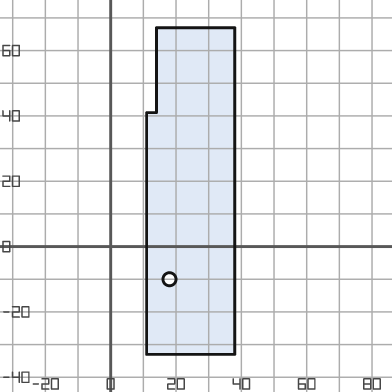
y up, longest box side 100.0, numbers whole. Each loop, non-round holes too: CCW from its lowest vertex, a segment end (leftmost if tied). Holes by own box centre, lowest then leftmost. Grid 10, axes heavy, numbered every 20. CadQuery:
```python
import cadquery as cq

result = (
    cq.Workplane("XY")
    .moveTo(11.0, -33.0)
    .lineTo(38.0, -33.0)
    .lineTo(38.0, 67.0)
    .lineTo(14.0, 67.0)
    .lineTo(14.0, 41.0)
    .lineTo(11.0, 41.0)
    .close()
    .moveTo(18.0, -10.0)
    .circle(2.0)
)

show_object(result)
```